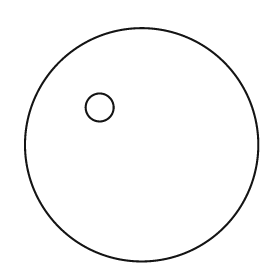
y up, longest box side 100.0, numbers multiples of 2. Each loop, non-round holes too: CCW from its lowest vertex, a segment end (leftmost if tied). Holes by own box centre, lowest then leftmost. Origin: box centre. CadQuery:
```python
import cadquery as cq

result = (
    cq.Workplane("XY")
    .moveTo(0.0, 0.0)
    .circle(50.0)
    .moveTo(-18.0, 16.0)
    .circle(6.0)
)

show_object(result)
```